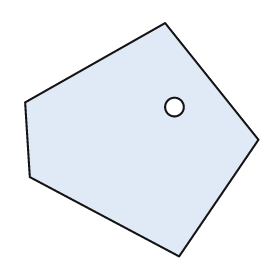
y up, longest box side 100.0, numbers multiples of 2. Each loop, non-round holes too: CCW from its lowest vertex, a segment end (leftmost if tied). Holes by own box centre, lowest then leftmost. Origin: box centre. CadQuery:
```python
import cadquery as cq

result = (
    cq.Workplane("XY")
    .moveTo(16.0, -50.0)
    .lineTo(50.0, 0.0)
    .lineTo(10.0, 50.0)
    .lineTo(-50.0, 16.0)
    .lineTo(-48.0, -16.0)
    .close()
    .moveTo(14.0, 14.0)
    .circle(4.0)
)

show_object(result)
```